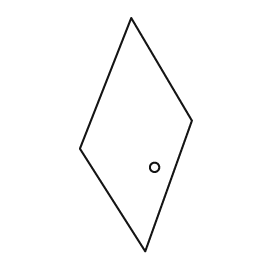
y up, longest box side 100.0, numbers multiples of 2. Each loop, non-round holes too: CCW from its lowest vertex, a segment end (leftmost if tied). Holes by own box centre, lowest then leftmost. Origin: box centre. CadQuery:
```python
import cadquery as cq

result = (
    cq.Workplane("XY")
    .moveTo(4.0, -50.0)
    .lineTo(24.0, 6.0)
    .lineTo(-2.0, 50.0)
    .lineTo(-24.0, -6.0)
    .close()
    .moveTo(8.0, -14.0)
    .circle(2.0)
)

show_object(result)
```